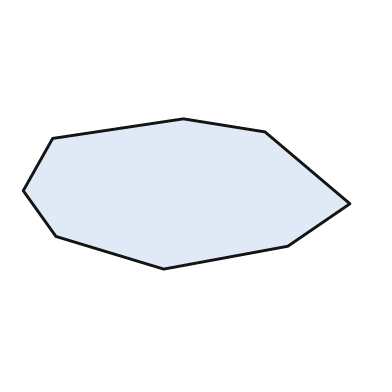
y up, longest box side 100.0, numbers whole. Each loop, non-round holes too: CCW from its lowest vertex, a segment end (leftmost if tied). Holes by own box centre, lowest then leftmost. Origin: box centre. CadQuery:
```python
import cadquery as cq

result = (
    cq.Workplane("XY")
    .moveTo(-7.0, -23.0)
    .lineTo(31.0, -16.0)
    .lineTo(50.0, -3.0)
    .lineTo(24.0, 19.0)
    .lineTo(-1.0, 23.0)
    .lineTo(-41.0, 17.0)
    .lineTo(-50.0, 1.0)
    .lineTo(-40.0, -13.0)
    .close()
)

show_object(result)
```